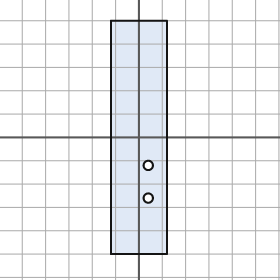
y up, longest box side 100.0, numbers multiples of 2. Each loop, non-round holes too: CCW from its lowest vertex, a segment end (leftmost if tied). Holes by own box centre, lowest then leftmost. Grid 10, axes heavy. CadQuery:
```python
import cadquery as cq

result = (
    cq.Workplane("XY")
    .moveTo(-12.0, -50.0)
    .lineTo(12.0, -50.0)
    .lineTo(12.0, 50.0)
    .lineTo(-12.0, 50.0)
    .close()
    .moveTo(4.0, -26.0)
    .circle(2.0)
    .moveTo(4.0, -12.0)
    .circle(2.0)
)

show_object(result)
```